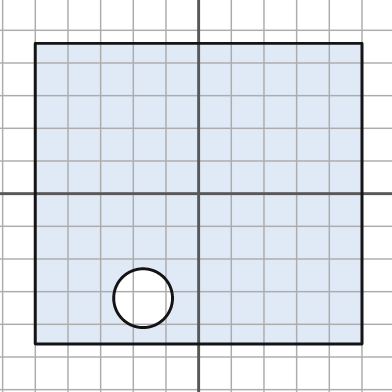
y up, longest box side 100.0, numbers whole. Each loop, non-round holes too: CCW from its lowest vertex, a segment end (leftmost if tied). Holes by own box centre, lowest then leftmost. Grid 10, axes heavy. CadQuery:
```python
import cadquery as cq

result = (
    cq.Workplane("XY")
    .moveTo(-50.0, -46.0)
    .lineTo(50.0, -46.0)
    .lineTo(50.0, 46.0)
    .lineTo(-50.0, 46.0)
    .close()
    .moveTo(-17.0, -32.0)
    .circle(9.0)
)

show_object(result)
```